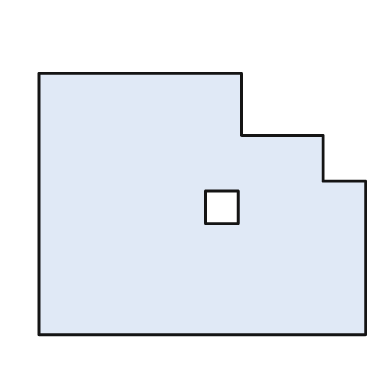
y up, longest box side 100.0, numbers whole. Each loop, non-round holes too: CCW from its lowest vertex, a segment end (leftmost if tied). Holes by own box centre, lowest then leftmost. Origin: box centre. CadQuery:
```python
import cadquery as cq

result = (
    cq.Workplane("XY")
    .moveTo(-50.0, -40.0)
    .lineTo(50.0, -40.0)
    .lineTo(50.0, 7.0)
    .lineTo(37.0, 7.0)
    .lineTo(37.0, 21.0)
    .lineTo(12.0, 21.0)
    .lineTo(12.0, 40.0)
    .lineTo(-50.0, 40.0)
    .close()
    .moveTo(1.0, -6.0)
    .lineTo(11.0, -6.0)
    .lineTo(11.0, 4.0)
    .lineTo(1.0, 4.0)
    .close()
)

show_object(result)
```